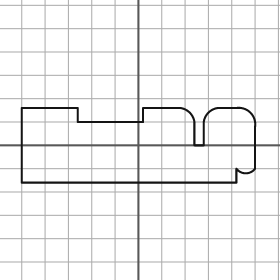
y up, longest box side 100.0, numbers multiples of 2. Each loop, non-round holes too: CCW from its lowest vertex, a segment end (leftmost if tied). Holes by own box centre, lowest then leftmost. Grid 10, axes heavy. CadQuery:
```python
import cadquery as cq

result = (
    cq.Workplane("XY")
    .moveTo(-50.0, -16.0)
    .lineTo(42.0, -16.0)
    .lineTo(42.0, -10.0)
    .threePointArc((46.0, -12.0), (50.0, -10.0))
    .lineTo(50.0, 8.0)
    .threePointArc((48.0, 14.0), (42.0, 16.0))
    .lineTo(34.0, 16.0)
    .threePointArc((30.0, 14.0), (28.0, 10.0))
    .lineTo(28.0, 0.0)
    .lineTo(24.0, 0.0)
    .lineTo(24.0, 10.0)
    .threePointArc((22.0, 14.0), (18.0, 16.0))
    .lineTo(2.0, 16.0)
    .lineTo(2.0, 10.0)
    .lineTo(-26.0, 10.0)
    .lineTo(-26.0, 16.0)
    .lineTo(-50.0, 16.0)
    .close()
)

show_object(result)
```